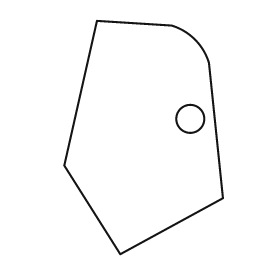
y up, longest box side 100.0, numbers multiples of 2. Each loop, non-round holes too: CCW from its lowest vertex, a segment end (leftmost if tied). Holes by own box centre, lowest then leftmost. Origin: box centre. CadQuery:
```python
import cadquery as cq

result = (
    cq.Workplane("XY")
    .moveTo(-10.0, -50.0)
    .lineTo(34.0, -26.0)
    .lineTo(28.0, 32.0)
    .threePointArc((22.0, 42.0), (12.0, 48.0))
    .lineTo(-20.0, 50.0)
    .lineTo(-34.0, -12.0)
    .close()
    .moveTo(20.0, 8.0)
    .circle(6.0)
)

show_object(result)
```